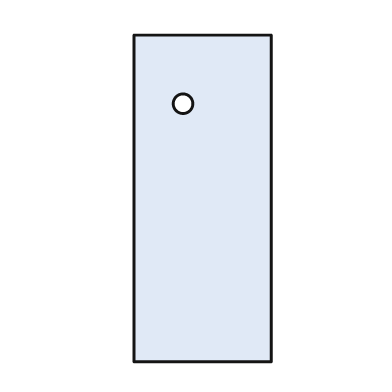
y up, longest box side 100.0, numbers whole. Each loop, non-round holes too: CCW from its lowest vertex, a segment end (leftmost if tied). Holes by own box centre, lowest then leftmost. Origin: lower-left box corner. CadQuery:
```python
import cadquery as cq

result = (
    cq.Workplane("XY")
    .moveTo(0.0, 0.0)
    .lineTo(42.0, 0.0)
    .lineTo(42.0, 100.0)
    .lineTo(0.0, 100.0)
    .close()
    .moveTo(15.0, 79.0)
    .circle(3.0)
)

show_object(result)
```